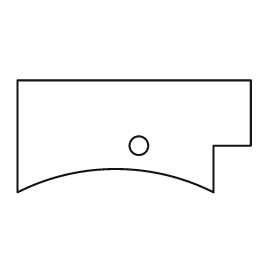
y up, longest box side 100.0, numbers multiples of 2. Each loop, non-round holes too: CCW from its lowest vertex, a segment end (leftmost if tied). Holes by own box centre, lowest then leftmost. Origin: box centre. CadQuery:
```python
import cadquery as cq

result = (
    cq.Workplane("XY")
    .moveTo(-50.0, -24.0)
    .threePointArc((-8.0, -14.0), (34.0, -24.0))
    .lineTo(34.0, -4.0)
    .lineTo(50.0, -4.0)
    .lineTo(50.0, 24.0)
    .lineTo(-50.0, 24.0)
    .close()
    .moveTo(2.0, -4.0)
    .circle(4.0)
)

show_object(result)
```